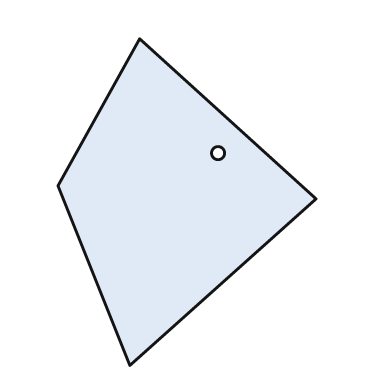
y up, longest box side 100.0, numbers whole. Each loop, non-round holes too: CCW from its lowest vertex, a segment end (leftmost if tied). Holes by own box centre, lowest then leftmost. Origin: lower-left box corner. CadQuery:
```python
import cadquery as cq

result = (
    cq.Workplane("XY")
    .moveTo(22.0, 0.0)
    .lineTo(79.0, 51.0)
    .lineTo(25.0, 100.0)
    .lineTo(0.0, 55.0)
    .close()
    .moveTo(49.0, 65.0)
    .circle(2.0)
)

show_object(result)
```